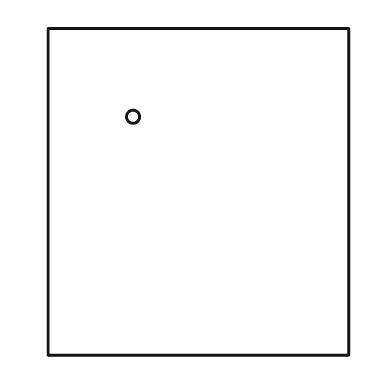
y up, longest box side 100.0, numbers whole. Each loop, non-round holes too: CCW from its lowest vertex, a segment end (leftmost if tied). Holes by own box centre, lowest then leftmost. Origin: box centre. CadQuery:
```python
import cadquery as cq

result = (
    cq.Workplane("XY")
    .moveTo(-46.0, -50.0)
    .lineTo(46.0, -50.0)
    .lineTo(46.0, 50.0)
    .lineTo(-46.0, 50.0)
    .close()
    .moveTo(-20.0, 23.0)
    .circle(2.0)
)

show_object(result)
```